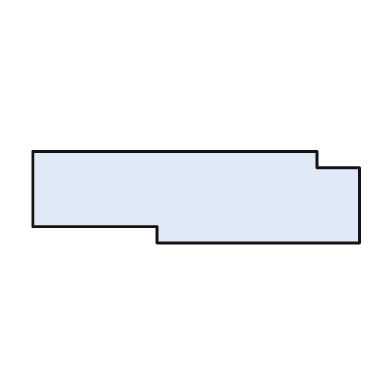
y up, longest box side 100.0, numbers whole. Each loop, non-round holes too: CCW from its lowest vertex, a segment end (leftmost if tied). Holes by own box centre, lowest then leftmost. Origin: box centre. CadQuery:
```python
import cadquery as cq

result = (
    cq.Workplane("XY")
    .moveTo(-12.0, -14.0)
    .lineTo(50.0, -14.0)
    .lineTo(50.0, 9.0)
    .lineTo(37.0, 9.0)
    .lineTo(37.0, 14.0)
    .lineTo(-50.0, 14.0)
    .lineTo(-50.0, -9.0)
    .lineTo(-12.0, -9.0)
    .close()
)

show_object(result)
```